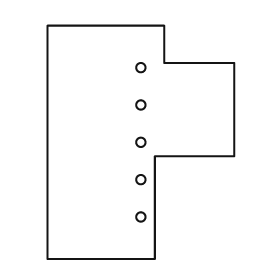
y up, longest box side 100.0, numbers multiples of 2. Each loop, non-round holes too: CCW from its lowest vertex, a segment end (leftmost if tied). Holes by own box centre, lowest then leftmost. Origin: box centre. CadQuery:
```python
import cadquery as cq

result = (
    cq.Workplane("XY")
    .moveTo(-40.0, -50.0)
    .lineTo(6.0, -50.0)
    .lineTo(6.0, -6.0)
    .lineTo(40.0, -6.0)
    .lineTo(40.0, 34.0)
    .lineTo(10.0, 34.0)
    .lineTo(10.0, 50.0)
    .lineTo(-40.0, 50.0)
    .close()
    .moveTo(0.0, -32.0)
    .circle(2.0)
    .moveTo(0.0, -16.0)
    .circle(2.0)
    .moveTo(0.0, 0.0)
    .circle(2.0)
    .moveTo(0.0, 16.0)
    .circle(2.0)
    .moveTo(0.0, 32.0)
    .circle(2.0)
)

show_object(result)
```